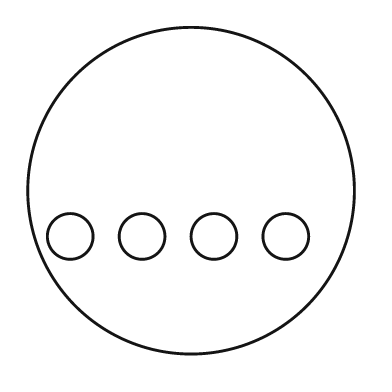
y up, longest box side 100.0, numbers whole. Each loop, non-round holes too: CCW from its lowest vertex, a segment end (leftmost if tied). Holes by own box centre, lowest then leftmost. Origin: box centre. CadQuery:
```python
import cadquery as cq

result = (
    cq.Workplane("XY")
    .moveTo(0.0, 0.0)
    .circle(50.0)
    .moveTo(-37.0, -14.0)
    .circle(7.0)
    .moveTo(-15.0, -14.0)
    .circle(7.0)
    .moveTo(7.0, -14.0)
    .circle(7.0)
    .moveTo(29.0, -14.0)
    .circle(7.0)
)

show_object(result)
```